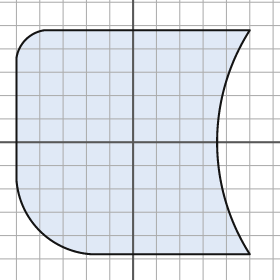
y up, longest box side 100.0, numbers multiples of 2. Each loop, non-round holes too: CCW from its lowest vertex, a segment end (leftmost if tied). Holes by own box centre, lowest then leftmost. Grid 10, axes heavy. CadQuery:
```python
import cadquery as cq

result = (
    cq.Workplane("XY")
    .moveTo(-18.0, -48.0)
    .lineTo(50.0, -48.0)
    .threePointArc((36.0, 0.0), (50.0, 48.0))
    .lineTo(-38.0, 48.0)
    .threePointArc((-46.0, 44.0), (-50.0, 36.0))
    .lineTo(-50.0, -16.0)
    .threePointArc((-40.0, -38.0), (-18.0, -48.0))
    .close()
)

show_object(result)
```